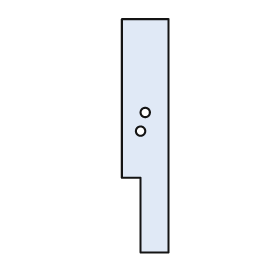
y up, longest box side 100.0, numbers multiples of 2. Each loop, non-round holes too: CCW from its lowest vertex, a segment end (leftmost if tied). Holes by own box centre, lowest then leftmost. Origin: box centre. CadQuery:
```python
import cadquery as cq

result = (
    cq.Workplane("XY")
    .moveTo(-2.0, -50.0)
    .lineTo(10.0, -50.0)
    .lineTo(10.0, 50.0)
    .lineTo(-10.0, 50.0)
    .lineTo(-10.0, -18.0)
    .lineTo(-2.0, -18.0)
    .close()
    .moveTo(-2.0, 2.0)
    .circle(2.0)
    .moveTo(0.0, 10.0)
    .circle(2.0)
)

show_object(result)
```